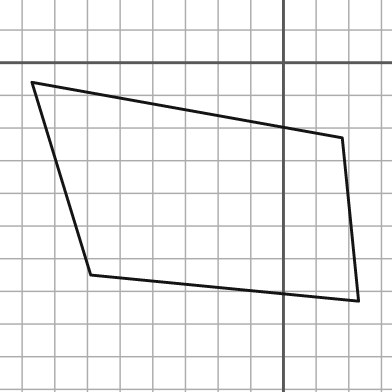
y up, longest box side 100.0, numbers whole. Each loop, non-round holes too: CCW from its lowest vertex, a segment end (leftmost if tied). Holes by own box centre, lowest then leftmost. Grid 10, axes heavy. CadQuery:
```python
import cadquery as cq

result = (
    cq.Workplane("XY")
    .moveTo(23.0, -73.0)
    .lineTo(18.0, -23.0)
    .lineTo(-77.0, -6.0)
    .lineTo(-59.0, -65.0)
    .close()
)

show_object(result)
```